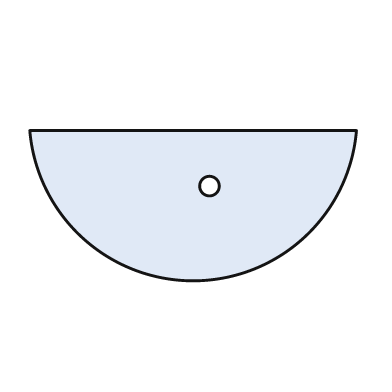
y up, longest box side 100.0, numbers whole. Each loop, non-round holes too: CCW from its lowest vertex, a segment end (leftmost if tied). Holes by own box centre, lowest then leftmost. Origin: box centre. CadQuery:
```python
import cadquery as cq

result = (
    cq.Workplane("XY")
    .moveTo(-50.0, 23.0)
    .threePointArc((0.0, -23.0), (50.0, 23.0))
    .close()
    .moveTo(5.0, 6.0)
    .circle(3.0)
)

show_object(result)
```